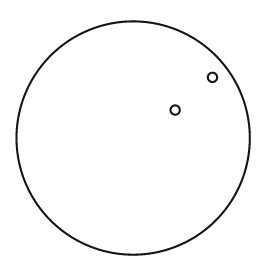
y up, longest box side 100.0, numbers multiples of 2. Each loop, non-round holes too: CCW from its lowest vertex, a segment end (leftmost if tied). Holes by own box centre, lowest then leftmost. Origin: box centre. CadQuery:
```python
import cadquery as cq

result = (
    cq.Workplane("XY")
    .moveTo(0.0, 0.0)
    .circle(50.0)
    .moveTo(18.0, 12.0)
    .circle(2.0)
    .moveTo(34.0, 26.0)
    .circle(2.0)
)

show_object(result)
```